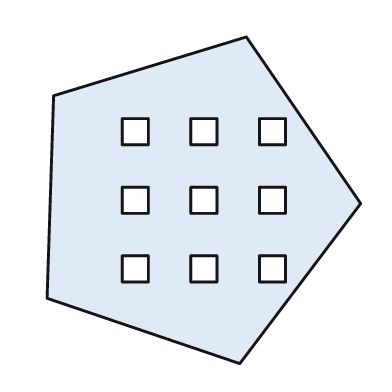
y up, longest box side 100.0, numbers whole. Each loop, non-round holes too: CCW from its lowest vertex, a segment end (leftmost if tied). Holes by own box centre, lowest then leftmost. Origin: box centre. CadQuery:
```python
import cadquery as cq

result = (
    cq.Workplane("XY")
    .moveTo(11.0, -50.0)
    .lineTo(48.0, -1.0)
    .lineTo(13.0, 50.0)
    .lineTo(-46.0, 32.0)
    .lineTo(-48.0, -30.0)
    .close()
    .moveTo(-25.0, -25.0)
    .lineTo(-17.0, -25.0)
    .lineTo(-17.0, -17.0)
    .lineTo(-25.0, -17.0)
    .close()
    .moveTo(-4.0, -25.0)
    .lineTo(4.0, -25.0)
    .lineTo(4.0, -17.0)
    .lineTo(-4.0, -17.0)
    .close()
    .moveTo(17.0, -25.0)
    .lineTo(25.0, -25.0)
    .lineTo(25.0, -17.0)
    .lineTo(17.0, -17.0)
    .close()
    .moveTo(-25.0, -4.0)
    .lineTo(-17.0, -4.0)
    .lineTo(-17.0, 4.0)
    .lineTo(-25.0, 4.0)
    .close()
    .moveTo(-4.0, -4.0)
    .lineTo(4.0, -4.0)
    .lineTo(4.0, 4.0)
    .lineTo(-4.0, 4.0)
    .close()
    .moveTo(17.0, -4.0)
    .lineTo(25.0, -4.0)
    .lineTo(25.0, 4.0)
    .lineTo(17.0, 4.0)
    .close()
    .moveTo(-25.0, 17.0)
    .lineTo(-17.0, 17.0)
    .lineTo(-17.0, 25.0)
    .lineTo(-25.0, 25.0)
    .close()
    .moveTo(-4.0, 17.0)
    .lineTo(4.0, 17.0)
    .lineTo(4.0, 25.0)
    .lineTo(-4.0, 25.0)
    .close()
    .moveTo(17.0, 17.0)
    .lineTo(25.0, 17.0)
    .lineTo(25.0, 25.0)
    .lineTo(17.0, 25.0)
    .close()
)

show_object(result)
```